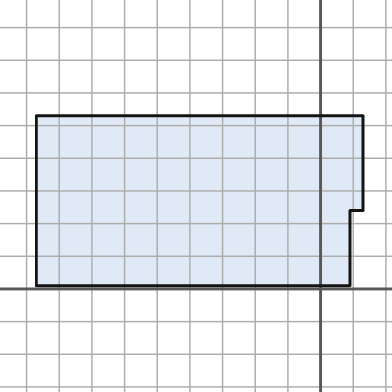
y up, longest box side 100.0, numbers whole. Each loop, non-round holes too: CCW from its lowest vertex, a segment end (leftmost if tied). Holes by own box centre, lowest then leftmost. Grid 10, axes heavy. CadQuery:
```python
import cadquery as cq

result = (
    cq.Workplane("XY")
    .moveTo(-87.0, 1.0)
    .lineTo(9.0, 1.0)
    .lineTo(9.0, 24.0)
    .lineTo(13.0, 24.0)
    .lineTo(13.0, 53.0)
    .lineTo(-87.0, 53.0)
    .close()
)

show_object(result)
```